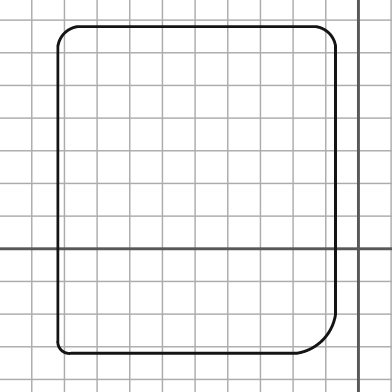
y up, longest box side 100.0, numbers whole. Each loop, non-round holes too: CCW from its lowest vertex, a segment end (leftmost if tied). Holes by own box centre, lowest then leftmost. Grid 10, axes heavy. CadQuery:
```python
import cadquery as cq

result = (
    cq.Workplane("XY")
    .moveTo(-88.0, -32.0)
    .lineTo(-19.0, -32.0)
    .threePointArc((-11.0, -28.0), (-7.0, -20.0))
    .lineTo(-7.0, 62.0)
    .threePointArc((-9.0, 66.0), (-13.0, 68.0))
    .lineTo(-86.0, 68.0)
    .threePointArc((-90.0, 66.0), (-92.0, 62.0))
    .lineTo(-92.0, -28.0)
    .threePointArc((-91.0, -31.0), (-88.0, -32.0))
    .close()
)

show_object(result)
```